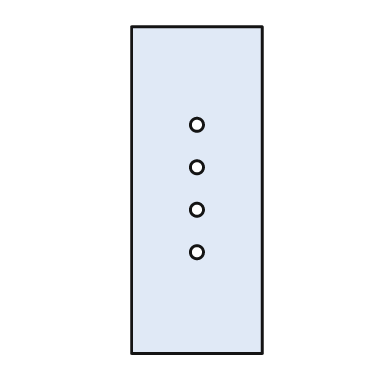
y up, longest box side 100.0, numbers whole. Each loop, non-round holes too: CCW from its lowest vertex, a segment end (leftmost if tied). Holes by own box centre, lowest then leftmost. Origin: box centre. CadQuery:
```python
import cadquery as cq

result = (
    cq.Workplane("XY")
    .moveTo(-20.0, -50.0)
    .lineTo(20.0, -50.0)
    .lineTo(20.0, 50.0)
    .lineTo(-20.0, 50.0)
    .close()
    .moveTo(0.0, -19.0)
    .circle(2.0)
    .moveTo(0.0, -6.0)
    .circle(2.0)
    .moveTo(0.0, 7.0)
    .circle(2.0)
    .moveTo(0.0, 20.0)
    .circle(2.0)
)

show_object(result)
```